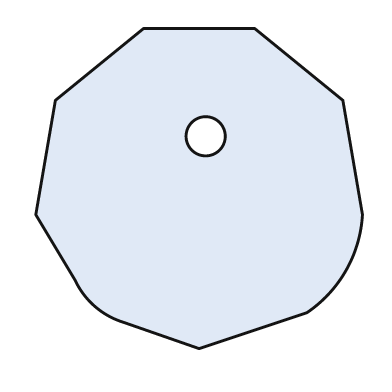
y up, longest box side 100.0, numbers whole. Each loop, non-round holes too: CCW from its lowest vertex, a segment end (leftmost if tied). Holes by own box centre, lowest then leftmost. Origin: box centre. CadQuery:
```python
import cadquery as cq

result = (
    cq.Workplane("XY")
    .moveTo(0.0, -49.0)
    .lineTo(33.0, -38.0)
    .threePointArc((45.0, -25.0), (50.0, -8.0))
    .lineTo(44.0, 27.0)
    .lineTo(17.0, 49.0)
    .lineTo(-17.0, 49.0)
    .lineTo(-44.0, 27.0)
    .lineTo(-50.0, -8.0)
    .lineTo(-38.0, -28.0)
    .threePointArc((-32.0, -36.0), (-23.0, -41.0))
    .close()
    .moveTo(2.0, 16.0)
    .circle(6.0)
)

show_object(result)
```